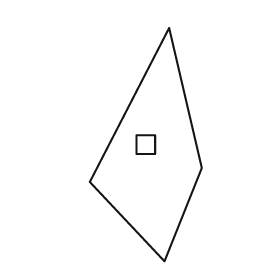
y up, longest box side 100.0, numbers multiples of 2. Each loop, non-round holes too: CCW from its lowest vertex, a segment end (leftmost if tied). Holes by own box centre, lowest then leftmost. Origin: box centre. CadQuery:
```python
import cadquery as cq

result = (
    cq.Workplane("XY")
    .moveTo(8.0, -50.0)
    .lineTo(24.0, -10.0)
    .lineTo(10.0, 50.0)
    .lineTo(-24.0, -16.0)
    .close()
    .moveTo(-4.0, -4.0)
    .lineTo(4.0, -4.0)
    .lineTo(4.0, 4.0)
    .lineTo(-4.0, 4.0)
    .close()
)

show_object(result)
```